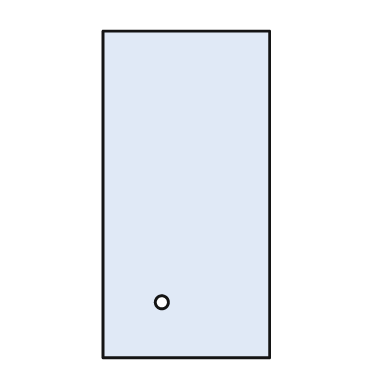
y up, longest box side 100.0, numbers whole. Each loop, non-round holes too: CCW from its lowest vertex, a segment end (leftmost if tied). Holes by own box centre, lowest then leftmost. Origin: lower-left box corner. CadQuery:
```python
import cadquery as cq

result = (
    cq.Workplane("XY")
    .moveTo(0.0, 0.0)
    .lineTo(51.0, 0.0)
    .lineTo(51.0, 100.0)
    .lineTo(0.0, 100.0)
    .close()
    .moveTo(18.0, 17.0)
    .circle(2.0)
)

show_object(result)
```